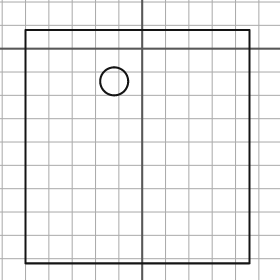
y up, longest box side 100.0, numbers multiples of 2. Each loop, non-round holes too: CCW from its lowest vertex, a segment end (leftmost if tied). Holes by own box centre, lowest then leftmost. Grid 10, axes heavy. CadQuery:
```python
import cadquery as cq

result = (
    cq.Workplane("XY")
    .moveTo(-50.0, -92.0)
    .lineTo(46.0, -92.0)
    .lineTo(46.0, 8.0)
    .lineTo(-50.0, 8.0)
    .close()
    .moveTo(-12.0, -14.0)
    .circle(6.0)
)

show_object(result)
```